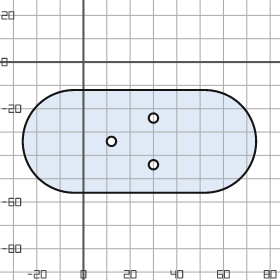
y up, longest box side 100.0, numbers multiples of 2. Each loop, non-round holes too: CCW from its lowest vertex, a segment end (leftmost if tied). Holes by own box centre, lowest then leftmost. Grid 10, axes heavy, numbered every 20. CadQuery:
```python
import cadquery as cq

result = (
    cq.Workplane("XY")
    .moveTo(-4.0, -56.0)
    .lineTo(52.0, -56.0)
    .threePointArc((74.0, -34.0), (52.0, -12.0))
    .lineTo(-4.0, -12.0)
    .threePointArc((-26.0, -34.0), (-4.0, -56.0))
    .close()
    .moveTo(30.0, -44.0)
    .circle(2.0)
    .moveTo(12.0, -34.0)
    .circle(2.0)
    .moveTo(30.0, -24.0)
    .circle(2.0)
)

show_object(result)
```